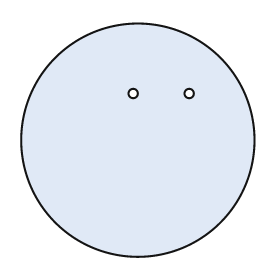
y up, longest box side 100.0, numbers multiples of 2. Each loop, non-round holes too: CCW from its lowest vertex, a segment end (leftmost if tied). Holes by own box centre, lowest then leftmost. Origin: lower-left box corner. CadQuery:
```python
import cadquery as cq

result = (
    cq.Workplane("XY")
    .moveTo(50.0, 50.0)
    .circle(50.0)
    .moveTo(48.0, 70.0)
    .circle(2.0)
    .moveTo(72.0, 70.0)
    .circle(2.0)
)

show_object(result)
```